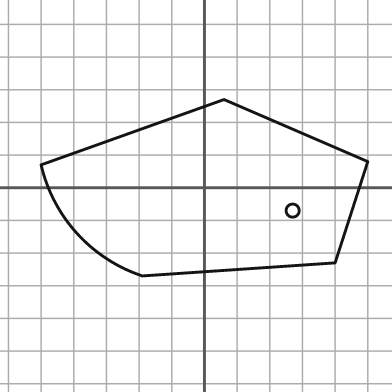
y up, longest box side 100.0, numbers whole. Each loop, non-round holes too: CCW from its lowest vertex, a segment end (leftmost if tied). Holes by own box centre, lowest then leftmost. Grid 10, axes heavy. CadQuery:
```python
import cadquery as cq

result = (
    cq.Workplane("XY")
    .moveTo(-19.0, -27.0)
    .lineTo(40.0, -23.0)
    .lineTo(50.0, 8.0)
    .lineTo(6.0, 27.0)
    .lineTo(-50.0, 7.0)
    .threePointArc((-39.0, -14.0), (-19.0, -27.0))
    .close()
    .moveTo(27.0, -7.0)
    .circle(2.0)
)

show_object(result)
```